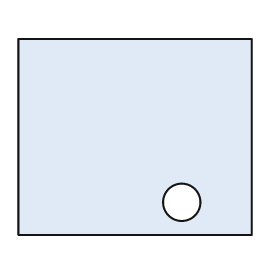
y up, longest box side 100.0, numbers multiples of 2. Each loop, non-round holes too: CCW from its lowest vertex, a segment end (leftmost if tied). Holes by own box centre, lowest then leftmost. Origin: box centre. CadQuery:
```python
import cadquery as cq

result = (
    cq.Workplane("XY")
    .moveTo(-50.0, -42.0)
    .lineTo(50.0, -42.0)
    .lineTo(50.0, 42.0)
    .lineTo(-50.0, 42.0)
    .close()
    .moveTo(20.0, -28.0)
    .circle(8.0)
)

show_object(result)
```